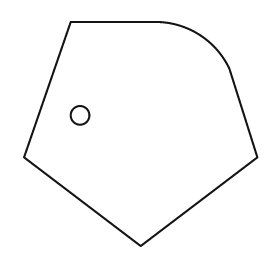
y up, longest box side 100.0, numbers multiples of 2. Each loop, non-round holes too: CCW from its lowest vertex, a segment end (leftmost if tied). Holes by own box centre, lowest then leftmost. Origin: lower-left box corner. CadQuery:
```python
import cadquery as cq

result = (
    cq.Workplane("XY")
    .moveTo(50.0, 0.0)
    .lineTo(100.0, 38.0)
    .lineTo(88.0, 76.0)
    .threePointArc((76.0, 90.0), (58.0, 96.0))
    .lineTo(20.0, 96.0)
    .lineTo(0.0, 38.0)
    .close()
    .moveTo(24.0, 56.0)
    .circle(4.0)
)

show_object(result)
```